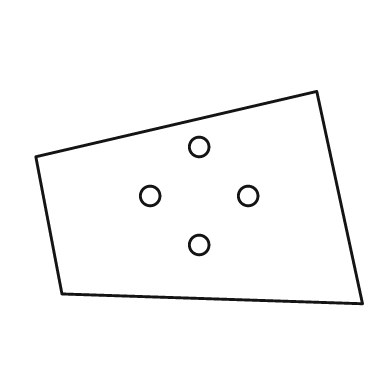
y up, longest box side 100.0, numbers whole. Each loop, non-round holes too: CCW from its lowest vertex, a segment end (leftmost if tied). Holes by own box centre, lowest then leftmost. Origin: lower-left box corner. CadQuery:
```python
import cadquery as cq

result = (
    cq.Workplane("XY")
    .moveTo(100.0, 0.0)
    .lineTo(86.0, 65.0)
    .lineTo(0.0, 45.0)
    .lineTo(8.0, 3.0)
    .close()
    .moveTo(50.0, 18.0)
    .circle(3.0)
    .moveTo(35.0, 33.0)
    .circle(3.0)
    .moveTo(65.0, 33.0)
    .circle(3.0)
    .moveTo(50.0, 48.0)
    .circle(3.0)
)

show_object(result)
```